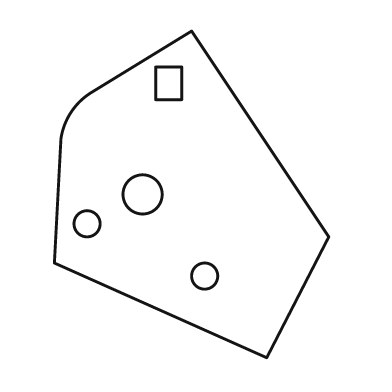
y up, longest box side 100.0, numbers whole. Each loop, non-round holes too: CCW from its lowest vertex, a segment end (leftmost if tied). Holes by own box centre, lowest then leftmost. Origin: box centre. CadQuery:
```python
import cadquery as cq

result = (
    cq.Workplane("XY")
    .moveTo(23.0, -50.0)
    .lineTo(42.0, -13.0)
    .lineTo(0.0, 50.0)
    .lineTo(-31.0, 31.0)
    .threePointArc((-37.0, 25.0), (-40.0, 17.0))
    .lineTo(-42.0, -21.0)
    .close()
    .moveTo(4.0, -25.0)
    .circle(4.0)
    .moveTo(-32.0, -9.0)
    .circle(4.0)
    .moveTo(-15.0, 0.0)
    .circle(6.0)
    .moveTo(-11.0, 29.0)
    .lineTo(-3.0, 29.0)
    .lineTo(-3.0, 39.0)
    .lineTo(-11.0, 39.0)
    .close()
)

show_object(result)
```